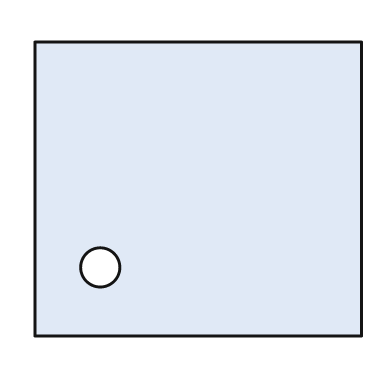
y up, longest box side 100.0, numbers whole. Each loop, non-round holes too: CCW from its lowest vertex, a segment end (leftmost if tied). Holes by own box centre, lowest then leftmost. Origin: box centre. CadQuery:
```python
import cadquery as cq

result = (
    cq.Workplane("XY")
    .moveTo(-50.0, -45.0)
    .lineTo(50.0, -45.0)
    .lineTo(50.0, 45.0)
    .lineTo(-50.0, 45.0)
    .close()
    .moveTo(-30.0, -24.0)
    .circle(6.0)
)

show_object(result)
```